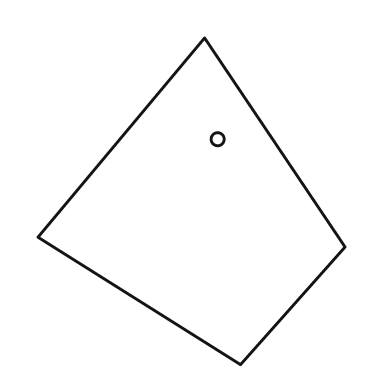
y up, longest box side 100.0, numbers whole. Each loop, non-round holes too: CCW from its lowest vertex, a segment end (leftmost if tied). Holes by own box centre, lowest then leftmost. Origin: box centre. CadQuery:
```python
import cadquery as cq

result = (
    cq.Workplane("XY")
    .moveTo(15.0, -50.0)
    .lineTo(47.0, -14.0)
    .lineTo(4.0, 50.0)
    .lineTo(-47.0, -11.0)
    .close()
    .moveTo(8.0, 19.0)
    .circle(2.0)
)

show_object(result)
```